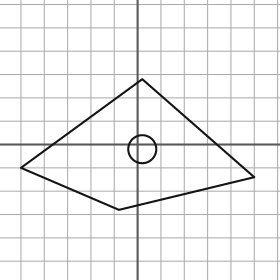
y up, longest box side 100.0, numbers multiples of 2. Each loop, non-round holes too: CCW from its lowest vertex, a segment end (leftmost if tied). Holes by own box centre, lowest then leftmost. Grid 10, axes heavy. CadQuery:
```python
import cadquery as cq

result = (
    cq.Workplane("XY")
    .moveTo(-8.0, -28.0)
    .lineTo(50.0, -14.0)
    .lineTo(2.0, 28.0)
    .lineTo(-50.0, -10.0)
    .close()
    .moveTo(2.0, -2.0)
    .circle(6.0)
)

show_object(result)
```